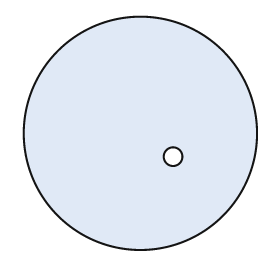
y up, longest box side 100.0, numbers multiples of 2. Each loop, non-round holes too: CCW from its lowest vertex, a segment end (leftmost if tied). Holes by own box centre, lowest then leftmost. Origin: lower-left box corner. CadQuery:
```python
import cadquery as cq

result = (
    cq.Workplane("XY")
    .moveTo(50.0, 50.0)
    .circle(50.0)
    .moveTo(64.0, 40.0)
    .circle(4.0)
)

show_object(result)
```